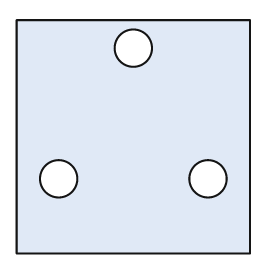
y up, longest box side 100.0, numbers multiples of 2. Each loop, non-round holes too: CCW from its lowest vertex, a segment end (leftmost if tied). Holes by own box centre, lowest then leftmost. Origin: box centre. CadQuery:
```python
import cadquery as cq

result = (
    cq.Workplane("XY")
    .moveTo(-50.0, -50.0)
    .lineTo(50.0, -50.0)
    .lineTo(50.0, 50.0)
    .lineTo(-50.0, 50.0)
    .close()
    .moveTo(-32.0, -18.0)
    .circle(8.0)
    .moveTo(32.0, -18.0)
    .circle(8.0)
    .moveTo(0.0, 38.0)
    .circle(8.0)
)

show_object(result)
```